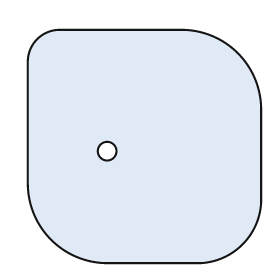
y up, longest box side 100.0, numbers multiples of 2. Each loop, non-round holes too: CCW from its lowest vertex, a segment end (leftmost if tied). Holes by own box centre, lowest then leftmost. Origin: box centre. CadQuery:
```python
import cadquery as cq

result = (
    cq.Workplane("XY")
    .moveTo(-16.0, -50.0)
    .lineTo(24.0, -50.0)
    .threePointArc((42.0, -42.0), (50.0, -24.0))
    .lineTo(50.0, 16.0)
    .threePointArc((40.0, 40.0), (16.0, 50.0))
    .lineTo(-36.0, 50.0)
    .threePointArc((-46.0, 46.0), (-50.0, 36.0))
    .lineTo(-50.0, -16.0)
    .threePointArc((-40.0, -40.0), (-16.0, -50.0))
    .close()
    .moveTo(-16.0, -2.0)
    .circle(4.0)
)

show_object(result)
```